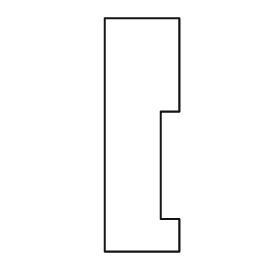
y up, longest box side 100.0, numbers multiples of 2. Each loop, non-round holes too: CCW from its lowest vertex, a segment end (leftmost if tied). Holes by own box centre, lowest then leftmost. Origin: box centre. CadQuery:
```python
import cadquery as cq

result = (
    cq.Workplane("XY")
    .moveTo(-16.0, -50.0)
    .lineTo(16.0, -50.0)
    .lineTo(16.0, -36.0)
    .lineTo(8.0, -36.0)
    .lineTo(8.0, 10.0)
    .lineTo(16.0, 10.0)
    .lineTo(16.0, 50.0)
    .lineTo(-16.0, 50.0)
    .close()
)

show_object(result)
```